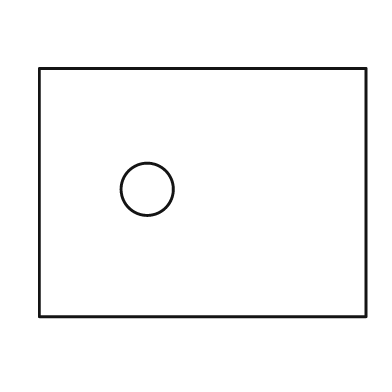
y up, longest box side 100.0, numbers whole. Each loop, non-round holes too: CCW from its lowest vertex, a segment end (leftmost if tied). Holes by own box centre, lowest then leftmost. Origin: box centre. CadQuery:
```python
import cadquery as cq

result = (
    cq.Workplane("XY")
    .moveTo(-50.0, -38.0)
    .lineTo(50.0, -38.0)
    .lineTo(50.0, 38.0)
    .lineTo(-50.0, 38.0)
    .close()
    .moveTo(-17.0, 1.0)
    .circle(8.0)
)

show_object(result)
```